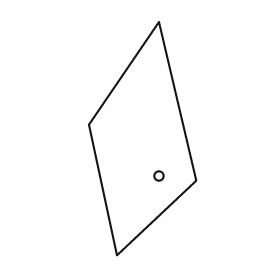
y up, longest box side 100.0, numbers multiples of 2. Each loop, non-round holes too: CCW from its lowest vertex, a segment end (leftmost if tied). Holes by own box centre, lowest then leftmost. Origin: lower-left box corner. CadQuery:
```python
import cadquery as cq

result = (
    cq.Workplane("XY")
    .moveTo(12.0, 0.0)
    .lineTo(46.0, 32.0)
    .lineTo(30.0, 100.0)
    .lineTo(0.0, 56.0)
    .close()
    .moveTo(30.0, 34.0)
    .circle(2.0)
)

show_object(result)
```